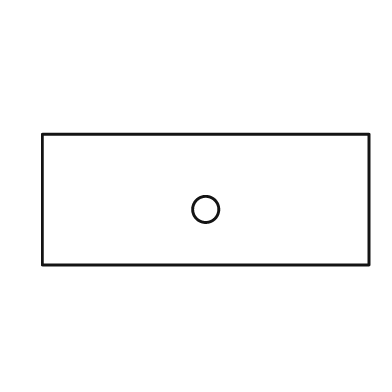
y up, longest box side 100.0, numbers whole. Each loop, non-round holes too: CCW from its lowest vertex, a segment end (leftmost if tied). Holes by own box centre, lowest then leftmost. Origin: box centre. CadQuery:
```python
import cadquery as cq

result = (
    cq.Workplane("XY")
    .moveTo(-50.0, -20.0)
    .lineTo(50.0, -20.0)
    .lineTo(50.0, 20.0)
    .lineTo(-50.0, 20.0)
    .close()
    .moveTo(0.0, -3.0)
    .circle(4.0)
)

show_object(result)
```